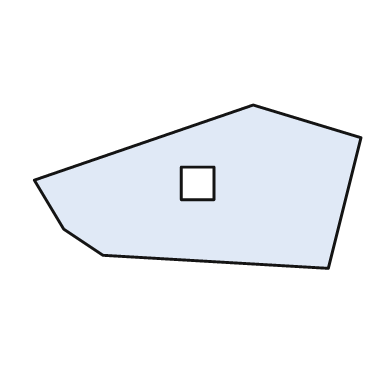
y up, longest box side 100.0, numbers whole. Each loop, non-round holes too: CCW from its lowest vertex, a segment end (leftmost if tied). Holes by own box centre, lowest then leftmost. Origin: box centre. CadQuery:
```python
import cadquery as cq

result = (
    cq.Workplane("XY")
    .moveTo(40.0, -25.0)
    .lineTo(50.0, 15.0)
    .lineTo(17.0, 25.0)
    .lineTo(-50.0, 2.0)
    .lineTo(-41.0, -13.0)
    .lineTo(-29.0, -21.0)
    .close()
    .moveTo(-5.0, -4.0)
    .lineTo(5.0, -4.0)
    .lineTo(5.0, 6.0)
    .lineTo(-5.0, 6.0)
    .close()
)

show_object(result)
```